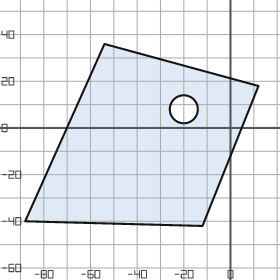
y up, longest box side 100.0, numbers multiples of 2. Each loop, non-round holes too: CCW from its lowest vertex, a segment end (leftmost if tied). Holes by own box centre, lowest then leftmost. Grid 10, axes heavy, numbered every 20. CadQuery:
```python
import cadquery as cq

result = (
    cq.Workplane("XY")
    .moveTo(-12.0, -42.0)
    .lineTo(12.0, 18.0)
    .lineTo(-54.0, 36.0)
    .lineTo(-88.0, -40.0)
    .close()
    .moveTo(-20.0, 8.0)
    .circle(6.0)
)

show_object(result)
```